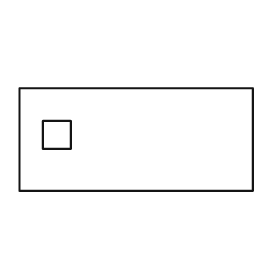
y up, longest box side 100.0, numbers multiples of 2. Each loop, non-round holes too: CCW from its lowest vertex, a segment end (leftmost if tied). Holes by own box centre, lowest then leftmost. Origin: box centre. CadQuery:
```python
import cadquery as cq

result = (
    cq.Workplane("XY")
    .moveTo(-50.0, -22.0)
    .lineTo(50.0, -22.0)
    .lineTo(50.0, 22.0)
    .lineTo(-50.0, 22.0)
    .close()
    .moveTo(-40.0, -4.0)
    .lineTo(-28.0, -4.0)
    .lineTo(-28.0, 8.0)
    .lineTo(-40.0, 8.0)
    .close()
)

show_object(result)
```